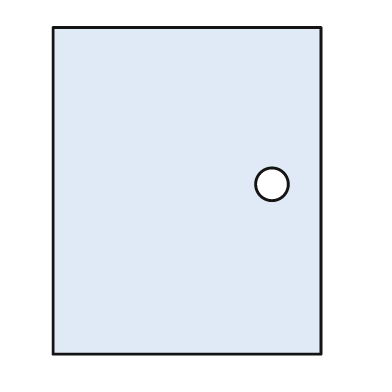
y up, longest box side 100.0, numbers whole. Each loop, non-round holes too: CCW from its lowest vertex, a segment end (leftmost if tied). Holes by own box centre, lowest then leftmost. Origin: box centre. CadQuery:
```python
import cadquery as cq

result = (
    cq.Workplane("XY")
    .moveTo(-41.0, -50.0)
    .lineTo(41.0, -50.0)
    .lineTo(41.0, 50.0)
    .lineTo(-41.0, 50.0)
    .close()
    .moveTo(26.0, 2.0)
    .circle(5.0)
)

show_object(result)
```